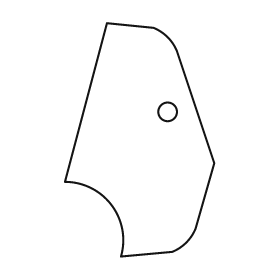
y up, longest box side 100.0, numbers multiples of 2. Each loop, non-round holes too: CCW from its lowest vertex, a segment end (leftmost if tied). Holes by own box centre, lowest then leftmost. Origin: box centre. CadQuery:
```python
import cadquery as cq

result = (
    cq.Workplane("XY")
    .moveTo(-8.0, -50.0)
    .lineTo(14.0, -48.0)
    .threePointArc((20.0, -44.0), (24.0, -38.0))
    .lineTo(32.0, -10.0)
    .lineTo(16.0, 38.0)
    .threePointArc((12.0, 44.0), (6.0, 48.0))
    .lineTo(-14.0, 50.0)
    .lineTo(-32.0, -18.0)
    .threePointArc((-12.0, -28.0), (-8.0, -50.0))
    .close()
    .moveTo(12.0, 12.0)
    .circle(4.0)
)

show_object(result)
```